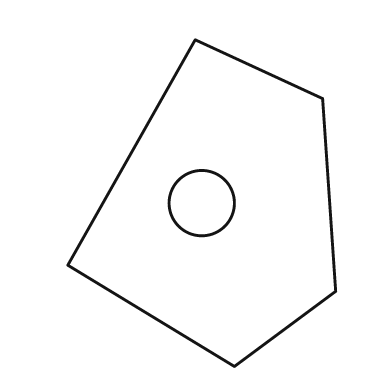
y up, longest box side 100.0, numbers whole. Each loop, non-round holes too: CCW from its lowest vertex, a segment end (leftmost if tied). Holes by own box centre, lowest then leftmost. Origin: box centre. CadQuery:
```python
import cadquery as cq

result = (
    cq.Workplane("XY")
    .moveTo(10.0, -50.0)
    .lineTo(41.0, -27.0)
    .lineTo(37.0, 32.0)
    .lineTo(-2.0, 50.0)
    .lineTo(-41.0, -19.0)
    .close()
    .moveTo(0.0, 0.0)
    .circle(10.0)
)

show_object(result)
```